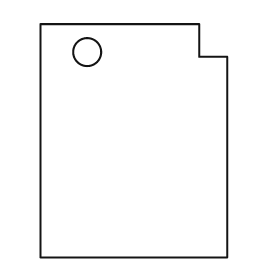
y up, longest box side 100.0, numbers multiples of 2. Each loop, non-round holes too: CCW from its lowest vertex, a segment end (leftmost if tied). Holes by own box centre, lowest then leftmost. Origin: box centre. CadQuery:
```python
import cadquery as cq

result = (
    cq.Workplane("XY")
    .moveTo(-40.0, -50.0)
    .lineTo(40.0, -50.0)
    .lineTo(40.0, 36.0)
    .lineTo(28.0, 36.0)
    .lineTo(28.0, 50.0)
    .lineTo(-40.0, 50.0)
    .close()
    .moveTo(-20.0, 38.0)
    .circle(6.0)
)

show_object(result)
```